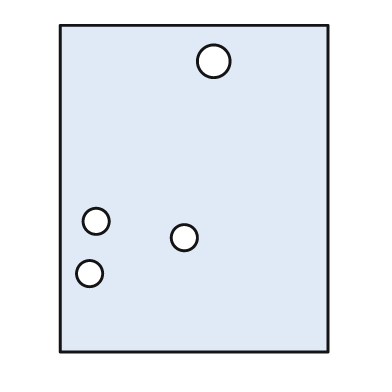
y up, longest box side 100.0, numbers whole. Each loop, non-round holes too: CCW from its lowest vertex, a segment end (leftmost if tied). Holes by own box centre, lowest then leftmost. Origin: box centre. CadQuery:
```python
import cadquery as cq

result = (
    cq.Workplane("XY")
    .moveTo(-41.0, -50.0)
    .lineTo(41.0, -50.0)
    .lineTo(41.0, 50.0)
    .lineTo(-41.0, 50.0)
    .close()
    .moveTo(-32.0, -26.0)
    .circle(4.0)
    .moveTo(-3.0, -15.0)
    .circle(4.0)
    .moveTo(-30.0, -10.0)
    .circle(4.0)
    .moveTo(6.0, 39.0)
    .circle(5.0)
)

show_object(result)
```